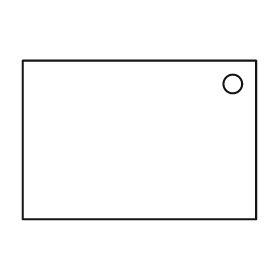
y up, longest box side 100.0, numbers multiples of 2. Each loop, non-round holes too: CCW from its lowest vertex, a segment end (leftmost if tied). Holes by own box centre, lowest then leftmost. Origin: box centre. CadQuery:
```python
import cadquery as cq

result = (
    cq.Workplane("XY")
    .moveTo(-50.0, -34.0)
    .lineTo(50.0, -34.0)
    .lineTo(50.0, 34.0)
    .lineTo(-50.0, 34.0)
    .close()
    .moveTo(40.0, 24.0)
    .circle(4.0)
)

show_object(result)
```